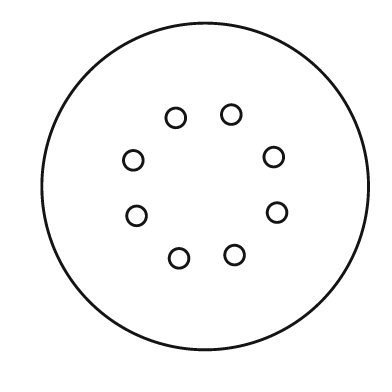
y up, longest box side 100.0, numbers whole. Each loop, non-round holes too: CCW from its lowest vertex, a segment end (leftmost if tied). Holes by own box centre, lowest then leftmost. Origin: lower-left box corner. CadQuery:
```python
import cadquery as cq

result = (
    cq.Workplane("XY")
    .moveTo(50.0, 50.0)
    .circle(50.0)
    .moveTo(42.0, 28.0)
    .circle(3.0)
    .moveTo(59.0, 29.0)
    .circle(3.0)
    .moveTo(29.0, 41.0)
    .circle(3.0)
    .moveTo(72.0, 42.0)
    .circle(3.0)
    .moveTo(28.0, 58.0)
    .circle(3.0)
    .moveTo(71.0, 59.0)
    .circle(3.0)
    .moveTo(41.0, 71.0)
    .circle(3.0)
    .moveTo(58.0, 72.0)
    .circle(3.0)
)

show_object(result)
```